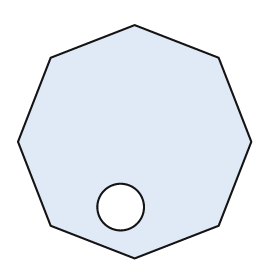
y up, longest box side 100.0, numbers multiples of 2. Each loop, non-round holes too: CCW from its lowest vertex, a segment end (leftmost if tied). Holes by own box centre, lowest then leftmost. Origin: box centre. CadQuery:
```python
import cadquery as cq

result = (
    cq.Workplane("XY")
    .moveTo(0.0, -50.0)
    .lineTo(36.0, -36.0)
    .lineTo(50.0, 0.0)
    .lineTo(36.0, 36.0)
    .lineTo(0.0, 50.0)
    .lineTo(-36.0, 36.0)
    .lineTo(-50.0, 0.0)
    .lineTo(-36.0, -36.0)
    .close()
    .moveTo(-6.0, -28.0)
    .circle(10.0)
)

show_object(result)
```